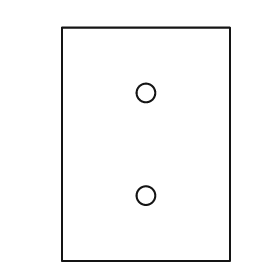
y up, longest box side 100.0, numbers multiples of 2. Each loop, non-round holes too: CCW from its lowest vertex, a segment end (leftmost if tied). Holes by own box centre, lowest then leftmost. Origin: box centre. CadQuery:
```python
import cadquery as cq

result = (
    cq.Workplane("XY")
    .moveTo(-36.0, -50.0)
    .lineTo(36.0, -50.0)
    .lineTo(36.0, 50.0)
    .lineTo(-36.0, 50.0)
    .close()
    .moveTo(0.0, -22.0)
    .circle(4.0)
    .moveTo(0.0, 22.0)
    .circle(4.0)
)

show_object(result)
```